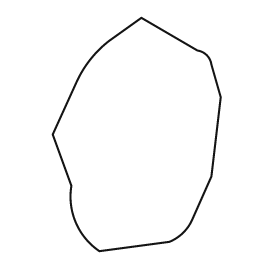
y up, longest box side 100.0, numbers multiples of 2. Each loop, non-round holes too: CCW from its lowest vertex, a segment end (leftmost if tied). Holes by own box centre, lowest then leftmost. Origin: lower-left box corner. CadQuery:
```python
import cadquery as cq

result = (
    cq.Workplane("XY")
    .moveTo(20.0, 0.0)
    .lineTo(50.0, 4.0)
    .threePointArc((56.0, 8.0), (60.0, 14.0))
    .lineTo(68.0, 32.0)
    .lineTo(72.0, 66.0)
    .lineTo(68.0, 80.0)
    .threePointArc((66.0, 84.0), (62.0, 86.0))
    .lineTo(38.0, 100.0)
    .lineTo(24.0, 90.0)
    .threePointArc((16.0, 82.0), (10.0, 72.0))
    .lineTo(0.0, 50.0)
    .lineTo(8.0, 28.0)
    .threePointArc((10.0, 12.0), (20.0, 0.0))
    .close()
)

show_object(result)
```